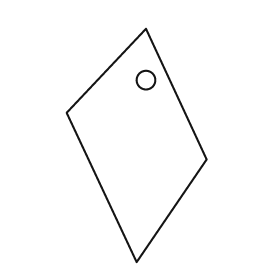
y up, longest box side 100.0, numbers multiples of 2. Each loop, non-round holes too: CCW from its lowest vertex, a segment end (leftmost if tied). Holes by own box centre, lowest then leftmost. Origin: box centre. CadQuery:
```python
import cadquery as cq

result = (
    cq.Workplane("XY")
    .moveTo(0.0, -50.0)
    .lineTo(30.0, -6.0)
    .lineTo(4.0, 50.0)
    .lineTo(-30.0, 14.0)
    .close()
    .moveTo(4.0, 28.0)
    .circle(4.0)
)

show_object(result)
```